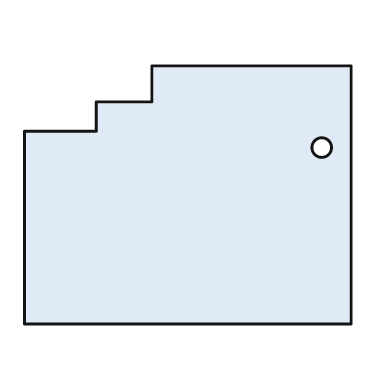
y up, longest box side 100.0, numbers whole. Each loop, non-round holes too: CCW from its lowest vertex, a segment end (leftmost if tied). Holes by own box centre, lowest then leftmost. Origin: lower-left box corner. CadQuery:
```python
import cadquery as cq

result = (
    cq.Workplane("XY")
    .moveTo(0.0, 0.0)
    .lineTo(100.0, 0.0)
    .lineTo(100.0, 79.0)
    .lineTo(39.0, 79.0)
    .lineTo(39.0, 68.0)
    .lineTo(22.0, 68.0)
    .lineTo(22.0, 59.0)
    .lineTo(0.0, 59.0)
    .close()
    .moveTo(91.0, 54.0)
    .circle(3.0)
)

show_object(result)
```